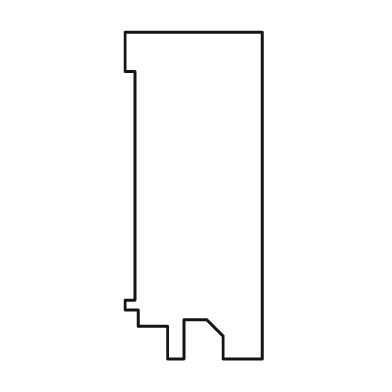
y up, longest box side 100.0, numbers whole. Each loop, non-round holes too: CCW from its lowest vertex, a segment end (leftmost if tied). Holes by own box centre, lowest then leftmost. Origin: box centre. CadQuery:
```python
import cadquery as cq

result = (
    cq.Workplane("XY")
    .moveTo(-8.0, -50.0)
    .lineTo(-3.0, -50.0)
    .lineTo(-3.0, -38.0)
    .lineTo(4.0, -38.0)
    .lineTo(9.0, -43.0)
    .lineTo(9.0, -50.0)
    .lineTo(21.0, -50.0)
    .lineTo(21.0, 50.0)
    .lineTo(-21.0, 50.0)
    .lineTo(-21.0, 38.0)
    .lineTo(-18.0, 38.0)
    .lineTo(-18.0, -32.0)
    .lineTo(-21.0, -32.0)
    .lineTo(-21.0, -35.0)
    .lineTo(-17.0, -35.0)
    .lineTo(-17.0, -40.0)
    .lineTo(-8.0, -40.0)
    .close()
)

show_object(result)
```